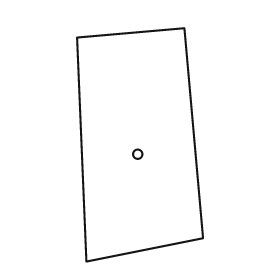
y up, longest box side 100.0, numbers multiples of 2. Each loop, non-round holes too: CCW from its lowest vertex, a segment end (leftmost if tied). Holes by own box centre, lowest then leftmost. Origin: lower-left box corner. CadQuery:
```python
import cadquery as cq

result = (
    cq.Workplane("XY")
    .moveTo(4.0, 0.0)
    .lineTo(54.0, 10.0)
    .lineTo(46.0, 100.0)
    .lineTo(0.0, 96.0)
    .close()
    .moveTo(26.0, 46.0)
    .circle(2.0)
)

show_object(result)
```